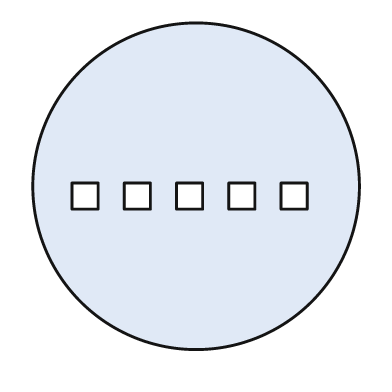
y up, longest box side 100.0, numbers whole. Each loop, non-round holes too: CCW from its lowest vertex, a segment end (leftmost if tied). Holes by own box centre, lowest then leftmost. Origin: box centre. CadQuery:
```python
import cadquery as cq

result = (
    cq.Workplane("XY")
    .moveTo(0.0, 0.0)
    .circle(50.0)
    .moveTo(-38.0, -7.0)
    .lineTo(-30.0, -7.0)
    .lineTo(-30.0, 1.0)
    .lineTo(-38.0, 1.0)
    .close()
    .moveTo(-22.0, -7.0)
    .lineTo(-14.0, -7.0)
    .lineTo(-14.0, 1.0)
    .lineTo(-22.0, 1.0)
    .close()
    .moveTo(-6.0, -7.0)
    .lineTo(2.0, -7.0)
    .lineTo(2.0, 1.0)
    .lineTo(-6.0, 1.0)
    .close()
    .moveTo(10.0, -7.0)
    .lineTo(18.0, -7.0)
    .lineTo(18.0, 1.0)
    .lineTo(10.0, 1.0)
    .close()
    .moveTo(26.0, -7.0)
    .lineTo(34.0, -7.0)
    .lineTo(34.0, 1.0)
    .lineTo(26.0, 1.0)
    .close()
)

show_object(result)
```